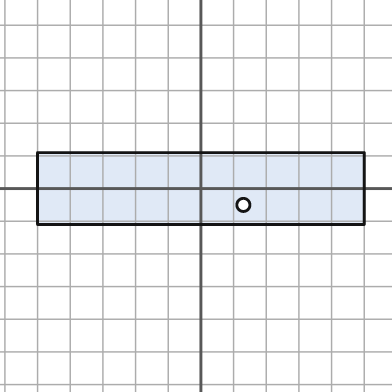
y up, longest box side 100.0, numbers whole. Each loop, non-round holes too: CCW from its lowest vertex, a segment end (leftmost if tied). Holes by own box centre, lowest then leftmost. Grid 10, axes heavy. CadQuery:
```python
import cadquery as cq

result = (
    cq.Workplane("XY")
    .moveTo(-50.0, -11.0)
    .lineTo(50.0, -11.0)
    .lineTo(50.0, 11.0)
    .lineTo(-50.0, 11.0)
    .close()
    .moveTo(13.0, -5.0)
    .circle(2.0)
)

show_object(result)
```